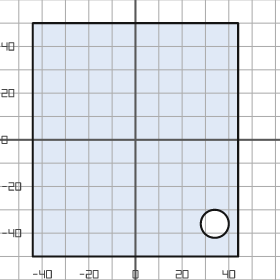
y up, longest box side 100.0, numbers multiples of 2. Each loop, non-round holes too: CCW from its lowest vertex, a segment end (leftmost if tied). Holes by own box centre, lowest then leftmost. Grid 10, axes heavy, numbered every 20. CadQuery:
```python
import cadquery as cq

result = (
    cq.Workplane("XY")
    .moveTo(-44.0, -50.0)
    .lineTo(44.0, -50.0)
    .lineTo(44.0, 50.0)
    .lineTo(-44.0, 50.0)
    .close()
    .moveTo(34.0, -36.0)
    .circle(6.0)
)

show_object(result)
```